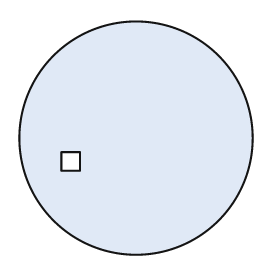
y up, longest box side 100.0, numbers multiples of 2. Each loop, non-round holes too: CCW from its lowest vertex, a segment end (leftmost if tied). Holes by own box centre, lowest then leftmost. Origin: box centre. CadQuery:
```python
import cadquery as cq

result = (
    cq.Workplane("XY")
    .moveTo(0.0, 0.0)
    .circle(50.0)
    .moveTo(-32.0, -14.0)
    .lineTo(-24.0, -14.0)
    .lineTo(-24.0, -6.0)
    .lineTo(-32.0, -6.0)
    .close()
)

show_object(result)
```